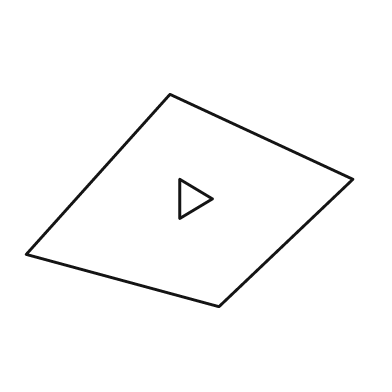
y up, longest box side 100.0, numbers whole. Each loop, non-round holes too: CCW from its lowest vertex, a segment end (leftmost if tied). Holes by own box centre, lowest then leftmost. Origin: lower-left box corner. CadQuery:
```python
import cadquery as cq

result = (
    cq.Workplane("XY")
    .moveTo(59.0, 0.0)
    .lineTo(100.0, 39.0)
    .lineTo(44.0, 65.0)
    .lineTo(0.0, 16.0)
    .close()
    .moveTo(47.0, 27.0)
    .lineTo(57.0, 33.0)
    .lineTo(47.0, 39.0)
    .close()
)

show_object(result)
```